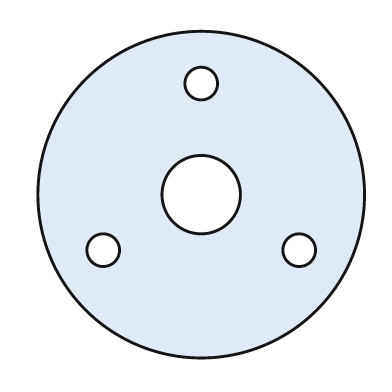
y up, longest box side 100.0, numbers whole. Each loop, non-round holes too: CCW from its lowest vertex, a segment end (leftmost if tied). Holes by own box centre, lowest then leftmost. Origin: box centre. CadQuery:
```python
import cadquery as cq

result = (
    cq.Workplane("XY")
    .moveTo(0.0, 0.0)
    .circle(50.0)
    .moveTo(-30.0, -17.0)
    .circle(5.0)
    .moveTo(30.0, -17.0)
    .circle(5.0)
    .moveTo(0.0, 0.0)
    .circle(12.0)
    .moveTo(0.0, 34.0)
    .circle(5.0)
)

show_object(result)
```